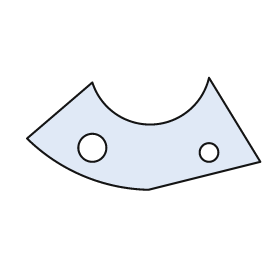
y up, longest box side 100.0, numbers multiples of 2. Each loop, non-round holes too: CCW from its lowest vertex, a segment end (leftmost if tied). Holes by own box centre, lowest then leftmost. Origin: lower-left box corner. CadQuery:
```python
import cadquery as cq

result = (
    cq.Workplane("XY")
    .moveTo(52.0, 0.0)
    .lineTo(100.0, 12.0)
    .lineTo(78.0, 48.0)
    .threePointArc((54.0, 28.0), (28.0, 46.0))
    .lineTo(0.0, 22.0)
    .threePointArc((24.0, 6.0), (52.0, 0.0))
    .close()
    .moveTo(78.0, 16.0)
    .circle(4.0)
    .moveTo(28.0, 18.0)
    .circle(6.0)
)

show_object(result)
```